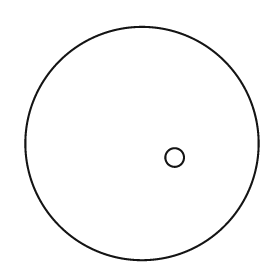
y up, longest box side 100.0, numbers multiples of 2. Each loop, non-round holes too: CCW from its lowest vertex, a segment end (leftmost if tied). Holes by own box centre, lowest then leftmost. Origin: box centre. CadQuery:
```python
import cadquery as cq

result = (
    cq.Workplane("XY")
    .moveTo(0.0, 0.0)
    .circle(50.0)
    .moveTo(14.0, -6.0)
    .circle(4.0)
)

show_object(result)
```